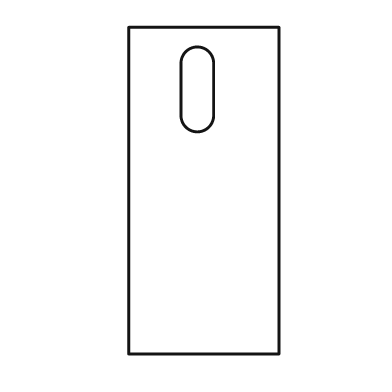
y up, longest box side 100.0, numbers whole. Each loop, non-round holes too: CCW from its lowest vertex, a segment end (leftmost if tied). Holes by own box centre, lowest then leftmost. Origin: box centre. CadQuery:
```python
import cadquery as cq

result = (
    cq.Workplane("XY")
    .moveTo(-23.0, -50.0)
    .lineTo(23.0, -50.0)
    .lineTo(23.0, 50.0)
    .lineTo(-23.0, 50.0)
    .close()
    .moveTo(-7.0, 23.0)
    .threePointArc((-2.0, 18.0), (3.0, 23.0))
    .lineTo(3.0, 39.0)
    .threePointArc((-2.0, 44.0), (-7.0, 39.0))
    .close()
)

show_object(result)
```